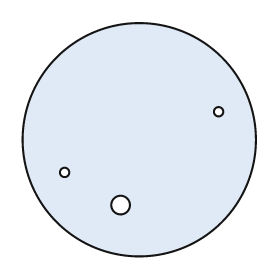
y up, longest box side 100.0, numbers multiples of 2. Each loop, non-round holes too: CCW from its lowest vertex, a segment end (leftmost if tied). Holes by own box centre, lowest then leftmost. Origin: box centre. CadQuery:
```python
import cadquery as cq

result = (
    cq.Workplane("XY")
    .moveTo(0.0, 0.0)
    .circle(50.0)
    .moveTo(-8.0, -28.0)
    .circle(4.0)
    .moveTo(-32.0, -14.0)
    .circle(2.0)
    .moveTo(34.0, 12.0)
    .circle(2.0)
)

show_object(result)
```